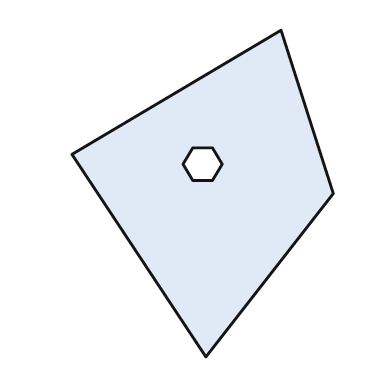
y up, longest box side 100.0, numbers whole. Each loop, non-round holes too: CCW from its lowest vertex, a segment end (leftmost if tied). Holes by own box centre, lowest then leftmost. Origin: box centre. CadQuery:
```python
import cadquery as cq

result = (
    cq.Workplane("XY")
    .moveTo(1.0, -50.0)
    .lineTo(40.0, 0.0)
    .lineTo(24.0, 50.0)
    .lineTo(-40.0, 12.0)
    .close()
    .moveTo(-3.0, 4.0)
    .lineTo(3.0, 4.0)
    .lineTo(6.0, 9.0)
    .lineTo(3.0, 14.0)
    .lineTo(-3.0, 14.0)
    .lineTo(-6.0, 9.0)
    .close()
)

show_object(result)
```